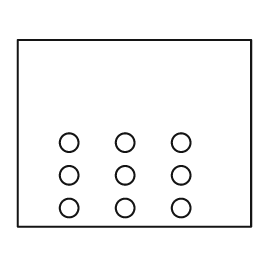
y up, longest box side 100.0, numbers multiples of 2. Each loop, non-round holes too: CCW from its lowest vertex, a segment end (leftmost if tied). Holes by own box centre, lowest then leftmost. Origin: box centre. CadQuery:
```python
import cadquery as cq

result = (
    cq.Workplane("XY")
    .moveTo(-50.0, -40.0)
    .lineTo(50.0, -40.0)
    .lineTo(50.0, 40.0)
    .lineTo(-50.0, 40.0)
    .close()
    .moveTo(-28.0, -32.0)
    .circle(4.0)
    .moveTo(-4.0, -32.0)
    .circle(4.0)
    .moveTo(20.0, -32.0)
    .circle(4.0)
    .moveTo(-28.0, -18.0)
    .circle(4.0)
    .moveTo(-4.0, -18.0)
    .circle(4.0)
    .moveTo(20.0, -18.0)
    .circle(4.0)
    .moveTo(-28.0, -4.0)
    .circle(4.0)
    .moveTo(-4.0, -4.0)
    .circle(4.0)
    .moveTo(20.0, -4.0)
    .circle(4.0)
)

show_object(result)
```